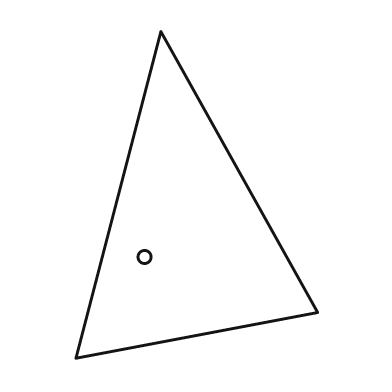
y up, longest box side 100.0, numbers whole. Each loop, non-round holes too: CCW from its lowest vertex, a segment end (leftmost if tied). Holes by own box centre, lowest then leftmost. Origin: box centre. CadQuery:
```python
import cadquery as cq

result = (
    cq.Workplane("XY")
    .moveTo(-37.0, -50.0)
    .lineTo(37.0, -36.0)
    .lineTo(-11.0, 50.0)
    .close()
    .moveTo(-16.0, -19.0)
    .circle(2.0)
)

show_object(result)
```